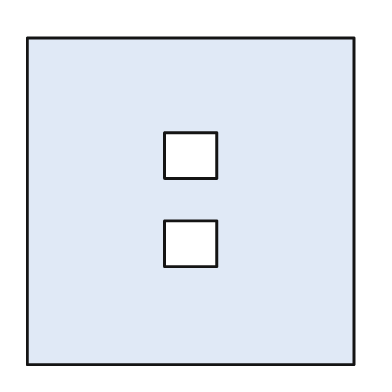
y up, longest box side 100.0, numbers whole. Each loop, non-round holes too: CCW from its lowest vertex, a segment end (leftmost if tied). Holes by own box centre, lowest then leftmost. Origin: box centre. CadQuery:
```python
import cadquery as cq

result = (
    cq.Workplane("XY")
    .moveTo(-50.0, -50.0)
    .lineTo(50.0, -50.0)
    .lineTo(50.0, 50.0)
    .lineTo(-50.0, 50.0)
    .close()
    .moveTo(-8.0, -20.0)
    .lineTo(8.0, -20.0)
    .lineTo(8.0, -6.0)
    .lineTo(-8.0, -6.0)
    .close()
    .moveTo(-8.0, 7.0)
    .lineTo(8.0, 7.0)
    .lineTo(8.0, 21.0)
    .lineTo(-8.0, 21.0)
    .close()
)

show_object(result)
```